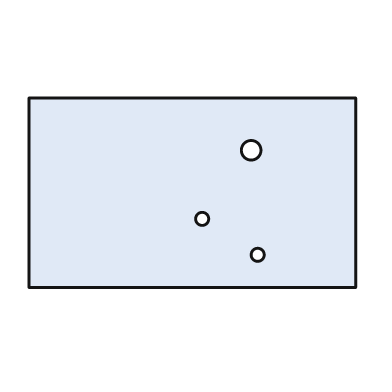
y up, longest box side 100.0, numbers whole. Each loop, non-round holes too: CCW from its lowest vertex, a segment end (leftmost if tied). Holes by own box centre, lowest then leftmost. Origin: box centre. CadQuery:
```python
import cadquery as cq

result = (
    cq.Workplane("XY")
    .moveTo(-50.0, -29.0)
    .lineTo(50.0, -29.0)
    .lineTo(50.0, 29.0)
    .lineTo(-50.0, 29.0)
    .close()
    .moveTo(20.0, -19.0)
    .circle(2.0)
    .moveTo(3.0, -8.0)
    .circle(2.0)
    .moveTo(18.0, 13.0)
    .circle(3.0)
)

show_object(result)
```